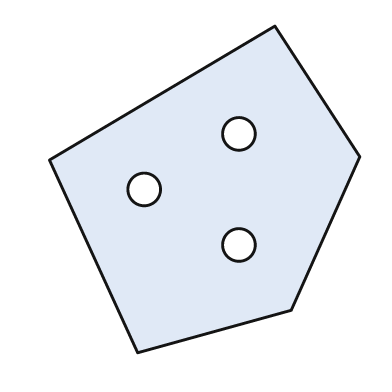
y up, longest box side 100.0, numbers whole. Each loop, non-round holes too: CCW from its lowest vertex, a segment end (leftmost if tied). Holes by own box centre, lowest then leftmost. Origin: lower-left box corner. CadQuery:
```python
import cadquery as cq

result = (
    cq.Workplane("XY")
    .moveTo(27.0, 0.0)
    .lineTo(74.0, 13.0)
    .lineTo(95.0, 60.0)
    .lineTo(69.0, 100.0)
    .lineTo(0.0, 59.0)
    .close()
    .moveTo(58.0, 33.0)
    .circle(5.0)
    .moveTo(29.0, 50.0)
    .circle(5.0)
    .moveTo(58.0, 67.0)
    .circle(5.0)
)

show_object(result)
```